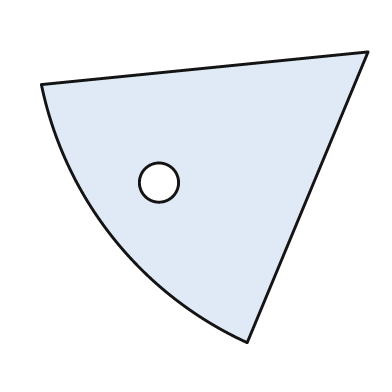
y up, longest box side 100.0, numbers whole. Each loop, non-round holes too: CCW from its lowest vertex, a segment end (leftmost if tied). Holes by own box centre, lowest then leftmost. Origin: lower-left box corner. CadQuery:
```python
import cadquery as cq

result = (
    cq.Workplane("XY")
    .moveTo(63.0, 0.0)
    .lineTo(100.0, 89.0)
    .lineTo(0.0, 79.0)
    .threePointArc((22.0, 32.0), (63.0, 0.0))
    .close()
    .moveTo(36.0, 49.0)
    .circle(6.0)
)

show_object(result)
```